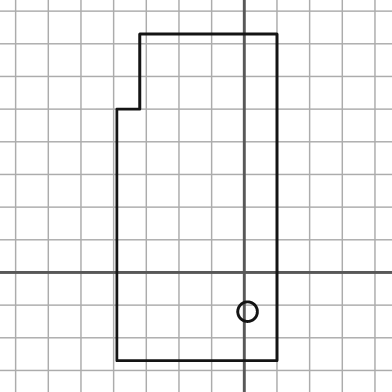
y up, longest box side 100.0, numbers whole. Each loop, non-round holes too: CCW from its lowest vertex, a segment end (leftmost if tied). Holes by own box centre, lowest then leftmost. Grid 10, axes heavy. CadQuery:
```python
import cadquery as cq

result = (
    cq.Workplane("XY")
    .moveTo(-39.0, -27.0)
    .lineTo(10.0, -27.0)
    .lineTo(10.0, 73.0)
    .lineTo(-32.0, 73.0)
    .lineTo(-32.0, 50.0)
    .lineTo(-39.0, 50.0)
    .close()
    .moveTo(1.0, -12.0)
    .circle(3.0)
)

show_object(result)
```